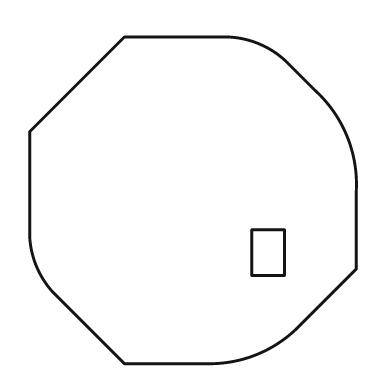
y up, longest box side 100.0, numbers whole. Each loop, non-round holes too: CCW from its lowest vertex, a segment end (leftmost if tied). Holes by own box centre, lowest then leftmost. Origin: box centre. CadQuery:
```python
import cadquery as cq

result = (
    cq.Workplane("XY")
    .moveTo(-21.0, -50.0)
    .lineTo(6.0, -50.0)
    .threePointArc((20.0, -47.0), (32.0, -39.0))
    .lineTo(50.0, -21.0)
    .lineTo(50.0, 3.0)
    .threePointArc((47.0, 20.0), (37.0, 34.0))
    .lineTo(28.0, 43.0)
    .threePointArc((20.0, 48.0), (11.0, 50.0))
    .lineTo(-21.0, 50.0)
    .lineTo(-50.0, 21.0)
    .lineTo(-50.0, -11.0)
    .threePointArc((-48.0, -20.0), (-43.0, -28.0))
    .close()
    .moveTo(18.0, -23.0)
    .lineTo(28.0, -23.0)
    .lineTo(28.0, -9.0)
    .lineTo(18.0, -9.0)
    .close()
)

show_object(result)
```